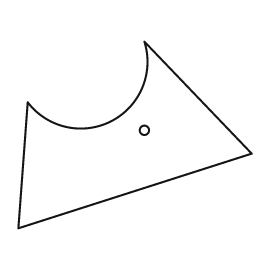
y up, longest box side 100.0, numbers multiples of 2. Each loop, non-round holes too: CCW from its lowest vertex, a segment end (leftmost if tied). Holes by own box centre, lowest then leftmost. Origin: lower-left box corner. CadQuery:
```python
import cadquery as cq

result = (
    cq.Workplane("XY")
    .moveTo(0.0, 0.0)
    .lineTo(100.0, 32.0)
    .lineTo(54.0, 80.0)
    .threePointArc((40.0, 46.0), (4.0, 54.0))
    .close()
    .moveTo(54.0, 42.0)
    .circle(2.0)
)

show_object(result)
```